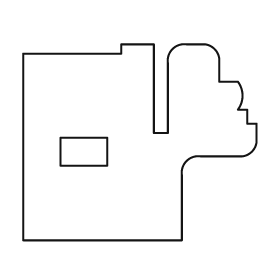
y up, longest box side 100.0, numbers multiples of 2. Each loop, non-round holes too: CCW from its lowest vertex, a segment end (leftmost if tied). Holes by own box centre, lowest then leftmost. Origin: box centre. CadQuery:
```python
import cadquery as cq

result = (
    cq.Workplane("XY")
    .moveTo(-50.0, -42.0)
    .lineTo(18.0, -42.0)
    .lineTo(18.0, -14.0)
    .threePointArc((20.0, -8.0), (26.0, -6.0))
    .lineTo(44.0, -6.0)
    .threePointArc((48.0, -4.0), (50.0, 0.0))
    .lineTo(50.0, 8.0)
    .lineTo(46.0, 8.0)
    .lineTo(46.0, 14.0)
    .lineTo(42.0, 14.0)
    .threePointArc((44.0, 20.0), (42.0, 26.0))
    .lineTo(34.0, 26.0)
    .lineTo(34.0, 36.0)
    .threePointArc((32.0, 40.0), (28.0, 42.0))
    .lineTo(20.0, 42.0)
    .threePointArc((14.0, 40.0), (12.0, 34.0))
    .lineTo(12.0, 4.0)
    .lineTo(6.0, 4.0)
    .lineTo(6.0, 42.0)
    .lineTo(-8.0, 42.0)
    .lineTo(-8.0, 38.0)
    .lineTo(-50.0, 38.0)
    .close()
    .moveTo(-34.0, -10.0)
    .lineTo(-14.0, -10.0)
    .lineTo(-14.0, 2.0)
    .lineTo(-34.0, 2.0)
    .close()
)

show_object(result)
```